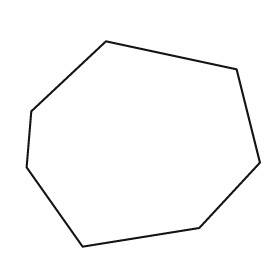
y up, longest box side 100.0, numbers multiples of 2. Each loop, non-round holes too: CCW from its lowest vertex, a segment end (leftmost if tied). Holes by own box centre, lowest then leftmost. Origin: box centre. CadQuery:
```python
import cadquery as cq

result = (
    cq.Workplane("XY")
    .moveTo(-26.0, -44.0)
    .lineTo(24.0, -36.0)
    .lineTo(50.0, -8.0)
    .lineTo(40.0, 32.0)
    .lineTo(-16.0, 44.0)
    .lineTo(-48.0, 14.0)
    .lineTo(-50.0, -10.0)
    .close()
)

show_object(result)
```